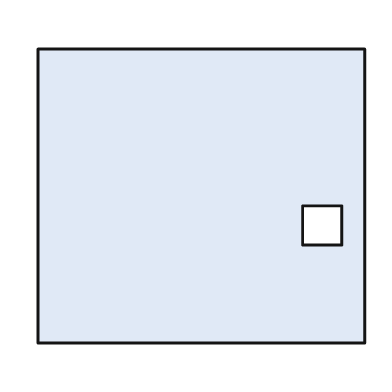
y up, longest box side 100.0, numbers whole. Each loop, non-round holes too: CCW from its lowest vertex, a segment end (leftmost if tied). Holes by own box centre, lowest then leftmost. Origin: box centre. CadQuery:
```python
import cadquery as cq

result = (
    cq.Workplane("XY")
    .moveTo(-50.0, -45.0)
    .lineTo(50.0, -45.0)
    .lineTo(50.0, 45.0)
    .lineTo(-50.0, 45.0)
    .close()
    .moveTo(31.0, -15.0)
    .lineTo(43.0, -15.0)
    .lineTo(43.0, -3.0)
    .lineTo(31.0, -3.0)
    .close()
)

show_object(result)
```